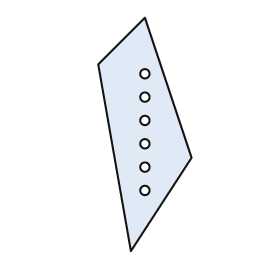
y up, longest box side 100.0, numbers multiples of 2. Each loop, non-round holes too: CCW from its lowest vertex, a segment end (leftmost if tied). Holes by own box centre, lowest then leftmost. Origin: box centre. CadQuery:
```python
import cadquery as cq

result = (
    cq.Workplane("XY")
    .moveTo(-6.0, -50.0)
    .lineTo(20.0, -10.0)
    .lineTo(0.0, 50.0)
    .lineTo(-20.0, 30.0)
    .close()
    .moveTo(0.0, -24.0)
    .circle(2.0)
    .moveTo(0.0, -14.0)
    .circle(2.0)
    .moveTo(0.0, -4.0)
    .circle(2.0)
    .moveTo(0.0, 6.0)
    .circle(2.0)
    .moveTo(0.0, 16.0)
    .circle(2.0)
    .moveTo(0.0, 26.0)
    .circle(2.0)
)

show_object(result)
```